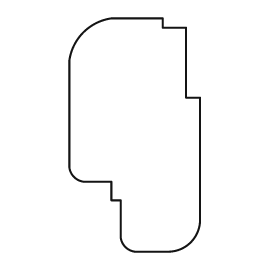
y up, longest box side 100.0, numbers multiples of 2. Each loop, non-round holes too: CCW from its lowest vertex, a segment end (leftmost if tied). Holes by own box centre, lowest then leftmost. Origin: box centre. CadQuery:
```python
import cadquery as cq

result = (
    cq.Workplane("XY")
    .moveTo(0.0, -50.0)
    .lineTo(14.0, -50.0)
    .threePointArc((24.0, -46.0), (28.0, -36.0))
    .lineTo(28.0, 16.0)
    .lineTo(22.0, 16.0)
    .lineTo(22.0, 46.0)
    .lineTo(12.0, 46.0)
    .lineTo(12.0, 50.0)
    .lineTo(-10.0, 50.0)
    .threePointArc((-22.0, 44.0), (-28.0, 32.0))
    .lineTo(-28.0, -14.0)
    .threePointArc((-26.0, -18.0), (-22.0, -20.0))
    .lineTo(-10.0, -20.0)
    .lineTo(-10.0, -28.0)
    .lineTo(-6.0, -28.0)
    .lineTo(-6.0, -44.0)
    .threePointArc((-4.0, -48.0), (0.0, -50.0))
    .close()
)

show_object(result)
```